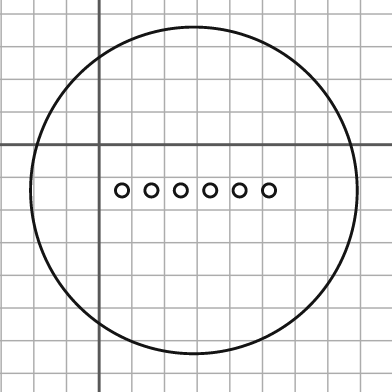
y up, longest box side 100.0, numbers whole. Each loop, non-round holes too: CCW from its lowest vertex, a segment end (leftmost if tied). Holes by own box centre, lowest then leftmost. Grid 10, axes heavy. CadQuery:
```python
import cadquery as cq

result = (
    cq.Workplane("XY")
    .moveTo(29.0, -14.0)
    .circle(50.0)
    .moveTo(7.0, -14.0)
    .circle(2.0)
    .moveTo(16.0, -14.0)
    .circle(2.0)
    .moveTo(25.0, -14.0)
    .circle(2.0)
    .moveTo(34.0, -14.0)
    .circle(2.0)
    .moveTo(43.0, -14.0)
    .circle(2.0)
    .moveTo(52.0, -14.0)
    .circle(2.0)
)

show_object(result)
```